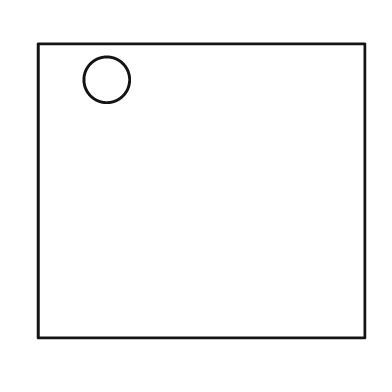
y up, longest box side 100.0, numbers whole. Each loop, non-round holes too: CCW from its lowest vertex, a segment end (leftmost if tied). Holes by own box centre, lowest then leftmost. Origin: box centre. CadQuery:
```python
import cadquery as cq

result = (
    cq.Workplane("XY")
    .moveTo(-50.0, -45.0)
    .lineTo(50.0, -45.0)
    .lineTo(50.0, 45.0)
    .lineTo(-50.0, 45.0)
    .close()
    .moveTo(-29.0, 34.0)
    .circle(7.0)
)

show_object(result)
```